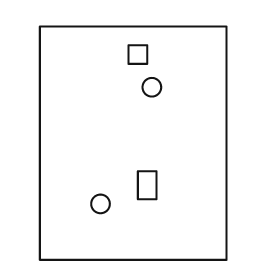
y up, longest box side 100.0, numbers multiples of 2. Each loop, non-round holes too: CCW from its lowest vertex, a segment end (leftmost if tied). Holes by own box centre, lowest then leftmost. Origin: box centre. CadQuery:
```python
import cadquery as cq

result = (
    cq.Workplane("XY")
    .moveTo(-40.0, -50.0)
    .lineTo(40.0, -50.0)
    .lineTo(40.0, 50.0)
    .lineTo(-40.0, 50.0)
    .close()
    .moveTo(-14.0, -26.0)
    .circle(4.0)
    .moveTo(2.0, -24.0)
    .lineTo(10.0, -24.0)
    .lineTo(10.0, -12.0)
    .lineTo(2.0, -12.0)
    .close()
    .moveTo(8.0, 24.0)
    .circle(4.0)
    .moveTo(-2.0, 34.0)
    .lineTo(6.0, 34.0)
    .lineTo(6.0, 42.0)
    .lineTo(-2.0, 42.0)
    .close()
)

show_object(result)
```